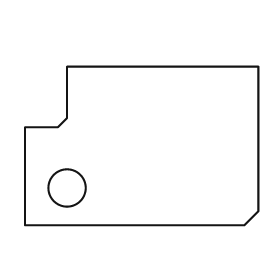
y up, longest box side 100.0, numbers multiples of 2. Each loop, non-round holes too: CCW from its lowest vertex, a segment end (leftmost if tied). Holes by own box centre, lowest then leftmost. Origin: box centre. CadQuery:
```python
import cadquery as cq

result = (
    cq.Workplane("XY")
    .moveTo(-50.0, -34.0)
    .lineTo(44.0, -34.0)
    .lineTo(50.0, -28.0)
    .lineTo(50.0, 34.0)
    .lineTo(-32.0, 34.0)
    .lineTo(-32.0, 12.0)
    .lineTo(-36.0, 8.0)
    .lineTo(-50.0, 8.0)
    .close()
    .moveTo(-32.0, -18.0)
    .circle(8.0)
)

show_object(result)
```